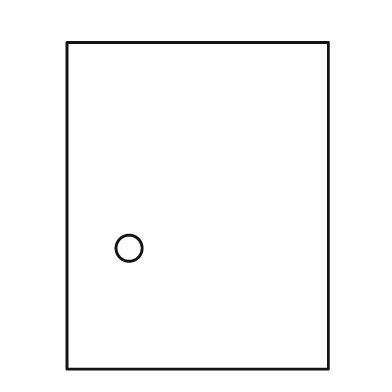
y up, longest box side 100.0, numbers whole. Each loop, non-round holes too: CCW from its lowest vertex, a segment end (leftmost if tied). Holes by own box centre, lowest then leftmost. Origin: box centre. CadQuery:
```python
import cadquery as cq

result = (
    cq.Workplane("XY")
    .moveTo(-40.0, -50.0)
    .lineTo(40.0, -50.0)
    .lineTo(40.0, 50.0)
    .lineTo(-40.0, 50.0)
    .close()
    .moveTo(-21.0, -13.0)
    .circle(4.0)
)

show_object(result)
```